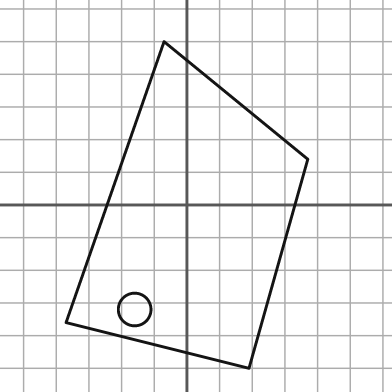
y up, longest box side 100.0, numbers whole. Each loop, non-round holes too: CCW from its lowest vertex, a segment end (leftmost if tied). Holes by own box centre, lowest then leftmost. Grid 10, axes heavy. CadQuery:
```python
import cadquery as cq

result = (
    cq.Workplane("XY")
    .moveTo(19.0, -50.0)
    .lineTo(37.0, 14.0)
    .lineTo(-7.0, 50.0)
    .lineTo(-37.0, -36.0)
    .close()
    .moveTo(-16.0, -32.0)
    .circle(5.0)
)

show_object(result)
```